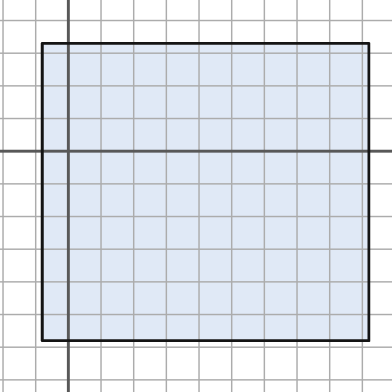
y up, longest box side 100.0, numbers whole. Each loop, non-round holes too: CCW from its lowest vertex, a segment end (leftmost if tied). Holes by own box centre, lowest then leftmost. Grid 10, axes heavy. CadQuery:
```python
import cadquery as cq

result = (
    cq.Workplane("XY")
    .moveTo(-8.0, -58.0)
    .lineTo(92.0, -58.0)
    .lineTo(92.0, 33.0)
    .lineTo(-8.0, 33.0)
    .close()
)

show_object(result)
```